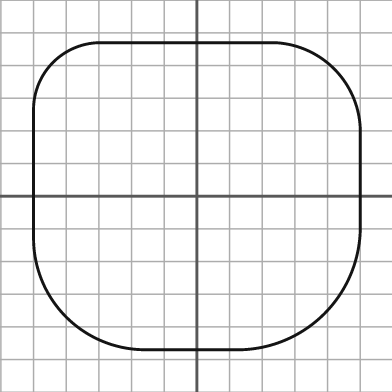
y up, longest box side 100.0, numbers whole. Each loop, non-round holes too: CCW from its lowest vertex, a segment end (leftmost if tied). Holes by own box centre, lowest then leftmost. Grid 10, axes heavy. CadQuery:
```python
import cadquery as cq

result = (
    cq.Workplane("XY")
    .moveTo(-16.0, -47.0)
    .lineTo(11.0, -47.0)
    .threePointArc((39.0, -36.0), (50.0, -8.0))
    .lineTo(50.0, 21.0)
    .threePointArc((42.0, 39.0), (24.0, 47.0))
    .lineTo(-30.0, 47.0)
    .threePointArc((-44.0, 41.0), (-50.0, 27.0))
    .lineTo(-50.0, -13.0)
    .threePointArc((-40.0, -37.0), (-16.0, -47.0))
    .close()
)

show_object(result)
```